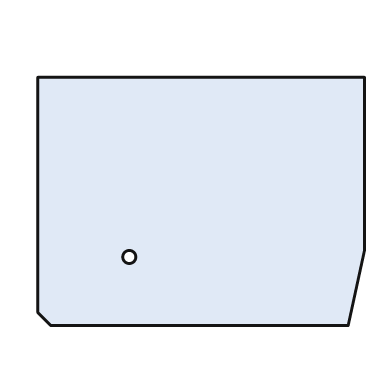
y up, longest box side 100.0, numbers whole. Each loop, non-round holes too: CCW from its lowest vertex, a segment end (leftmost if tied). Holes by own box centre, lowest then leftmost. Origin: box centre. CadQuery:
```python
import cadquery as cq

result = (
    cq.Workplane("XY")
    .moveTo(-46.0, -38.0)
    .lineTo(45.0, -38.0)
    .lineTo(50.0, -15.0)
    .lineTo(50.0, 38.0)
    .lineTo(-50.0, 38.0)
    .lineTo(-50.0, -34.0)
    .close()
    .moveTo(-22.0, -17.0)
    .circle(2.0)
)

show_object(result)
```